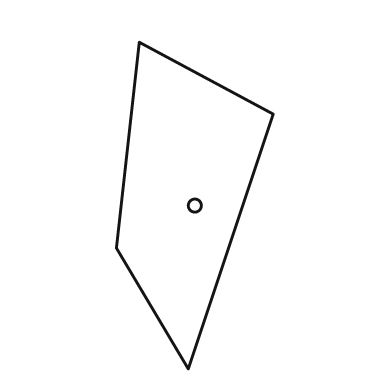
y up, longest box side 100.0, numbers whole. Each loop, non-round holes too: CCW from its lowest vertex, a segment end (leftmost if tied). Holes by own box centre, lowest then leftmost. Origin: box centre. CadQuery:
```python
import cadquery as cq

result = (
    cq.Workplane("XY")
    .moveTo(-2.0, -50.0)
    .lineTo(24.0, 28.0)
    .lineTo(-17.0, 50.0)
    .lineTo(-24.0, -13.0)
    .close()
    .moveTo(0.0, 0.0)
    .circle(2.0)
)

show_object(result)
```